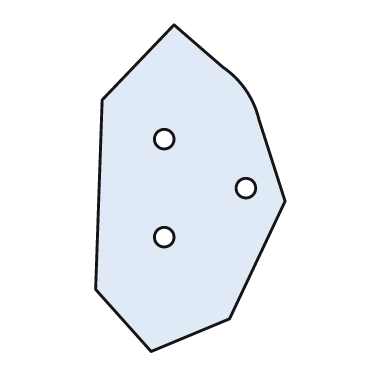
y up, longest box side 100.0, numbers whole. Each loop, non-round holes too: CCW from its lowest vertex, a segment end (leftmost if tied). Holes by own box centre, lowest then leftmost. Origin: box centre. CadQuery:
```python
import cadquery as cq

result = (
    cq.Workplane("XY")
    .moveTo(-12.0, -50.0)
    .lineTo(12.0, -40.0)
    .lineTo(29.0, -4.0)
    .lineTo(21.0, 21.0)
    .threePointArc((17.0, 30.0), (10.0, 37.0))
    .lineTo(-5.0, 50.0)
    .lineTo(-27.0, 27.0)
    .lineTo(-29.0, -31.0)
    .close()
    .moveTo(-8.0, -15.0)
    .circle(3.0)
    .moveTo(17.0, 0.0)
    .circle(3.0)
    .moveTo(-8.0, 15.0)
    .circle(3.0)
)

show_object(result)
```